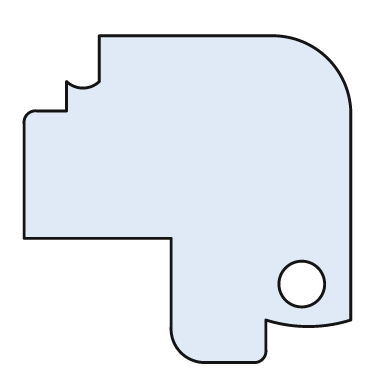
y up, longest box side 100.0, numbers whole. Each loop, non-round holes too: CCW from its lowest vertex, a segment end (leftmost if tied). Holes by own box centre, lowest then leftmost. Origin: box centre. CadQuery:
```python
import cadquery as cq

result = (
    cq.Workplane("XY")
    .moveTo(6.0, -50.0)
    .lineTo(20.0, -50.0)
    .threePointArc((23.0, -49.0), (24.0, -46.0))
    .lineTo(24.0, -37.0)
    .threePointArc((37.0, -39.0), (50.0, -37.0))
    .lineTo(50.0, 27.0)
    .threePointArc((43.0, 43.0), (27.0, 50.0))
    .lineTo(-27.0, 50.0)
    .lineTo(-27.0, 36.0)
    .threePointArc((-32.0, 34.0), (-37.0, 36.0))
    .lineTo(-37.0, 27.0)
    .lineTo(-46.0, 27.0)
    .threePointArc((-49.0, 26.0), (-50.0, 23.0))
    .lineTo(-50.0, -12.0)
    .lineTo(-5.0, -12.0)
    .lineTo(-5.0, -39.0)
    .threePointArc((-2.0, -47.0), (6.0, -50.0))
    .close()
    .moveTo(35.0, -26.0)
    .circle(7.0)
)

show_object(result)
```